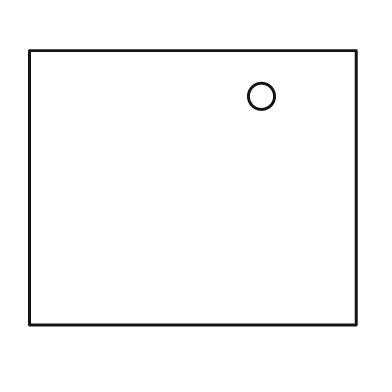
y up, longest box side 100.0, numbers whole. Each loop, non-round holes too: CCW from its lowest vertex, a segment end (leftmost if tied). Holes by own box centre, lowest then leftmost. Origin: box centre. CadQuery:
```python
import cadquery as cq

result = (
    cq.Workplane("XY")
    .moveTo(-50.0, -42.0)
    .lineTo(50.0, -42.0)
    .lineTo(50.0, 42.0)
    .lineTo(-50.0, 42.0)
    .close()
    .moveTo(21.0, 28.0)
    .circle(4.0)
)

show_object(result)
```